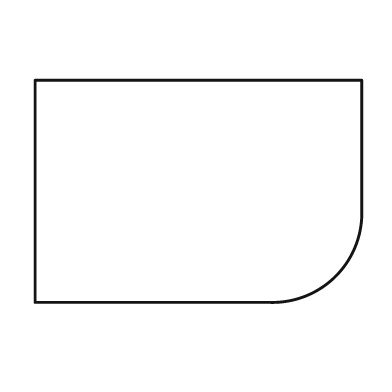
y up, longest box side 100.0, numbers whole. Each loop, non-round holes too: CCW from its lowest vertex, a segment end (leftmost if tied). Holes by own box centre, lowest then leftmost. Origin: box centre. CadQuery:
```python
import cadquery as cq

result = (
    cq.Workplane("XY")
    .moveTo(-50.0, -34.0)
    .lineTo(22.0, -34.0)
    .threePointArc((42.0, -26.0), (50.0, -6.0))
    .lineTo(50.0, 34.0)
    .lineTo(-50.0, 34.0)
    .close()
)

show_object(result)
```